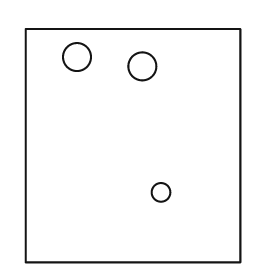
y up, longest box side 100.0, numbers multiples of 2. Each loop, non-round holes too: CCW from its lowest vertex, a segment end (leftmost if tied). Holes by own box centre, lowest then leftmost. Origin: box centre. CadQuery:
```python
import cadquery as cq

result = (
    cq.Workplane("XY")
    .moveTo(-46.0, -50.0)
    .lineTo(46.0, -50.0)
    .lineTo(46.0, 50.0)
    .lineTo(-46.0, 50.0)
    .close()
    .moveTo(12.0, -20.0)
    .circle(4.0)
    .moveTo(4.0, 34.0)
    .circle(6.0)
    .moveTo(-24.0, 38.0)
    .circle(6.0)
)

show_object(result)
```